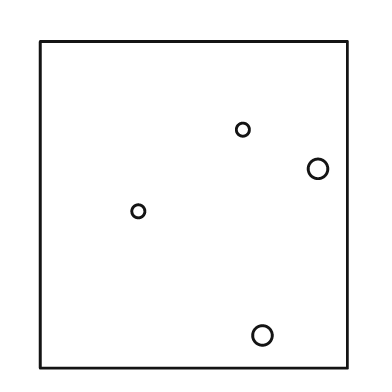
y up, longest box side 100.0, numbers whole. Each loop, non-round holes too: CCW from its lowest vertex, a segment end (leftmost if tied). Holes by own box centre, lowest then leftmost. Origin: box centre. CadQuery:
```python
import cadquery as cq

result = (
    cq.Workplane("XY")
    .moveTo(-47.0, -50.0)
    .lineTo(47.0, -50.0)
    .lineTo(47.0, 50.0)
    .lineTo(-47.0, 50.0)
    .close()
    .moveTo(21.0, -40.0)
    .circle(3.0)
    .moveTo(-17.0, -2.0)
    .circle(2.0)
    .moveTo(38.0, 11.0)
    .circle(3.0)
    .moveTo(15.0, 23.0)
    .circle(2.0)
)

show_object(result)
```